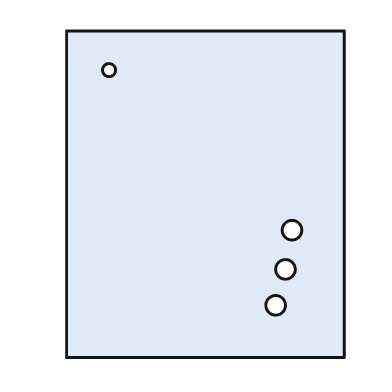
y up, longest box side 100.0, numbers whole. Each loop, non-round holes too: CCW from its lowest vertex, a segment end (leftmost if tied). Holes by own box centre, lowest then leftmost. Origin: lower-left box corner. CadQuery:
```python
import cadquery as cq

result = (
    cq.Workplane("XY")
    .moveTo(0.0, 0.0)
    .lineTo(85.0, 0.0)
    .lineTo(85.0, 100.0)
    .lineTo(0.0, 100.0)
    .close()
    .moveTo(64.0, 16.0)
    .circle(3.0)
    .moveTo(67.0, 27.0)
    .circle(3.0)
    .moveTo(69.0, 39.0)
    .circle(3.0)
    .moveTo(13.0, 88.0)
    .circle(2.0)
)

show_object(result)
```